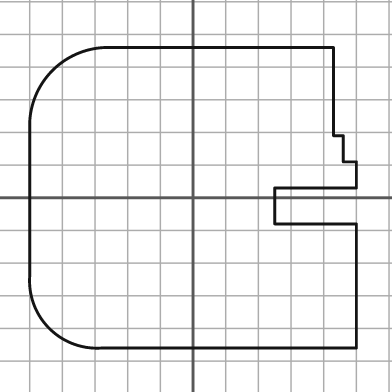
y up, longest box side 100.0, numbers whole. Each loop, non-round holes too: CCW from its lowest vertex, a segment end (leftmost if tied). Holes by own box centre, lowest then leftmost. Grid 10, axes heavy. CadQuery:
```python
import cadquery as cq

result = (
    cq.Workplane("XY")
    .moveTo(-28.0, -46.0)
    .lineTo(50.0, -46.0)
    .lineTo(50.0, -8.0)
    .lineTo(25.0, -8.0)
    .lineTo(25.0, 3.0)
    .lineTo(50.0, 3.0)
    .lineTo(50.0, 11.0)
    .lineTo(46.0, 11.0)
    .lineTo(46.0, 19.0)
    .lineTo(43.0, 19.0)
    .lineTo(43.0, 46.0)
    .lineTo(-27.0, 46.0)
    .threePointArc((-43.0, 39.0), (-50.0, 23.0))
    .lineTo(-50.0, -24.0)
    .threePointArc((-44.0, -40.0), (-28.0, -46.0))
    .close()
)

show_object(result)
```